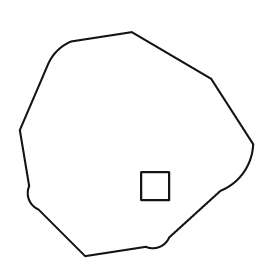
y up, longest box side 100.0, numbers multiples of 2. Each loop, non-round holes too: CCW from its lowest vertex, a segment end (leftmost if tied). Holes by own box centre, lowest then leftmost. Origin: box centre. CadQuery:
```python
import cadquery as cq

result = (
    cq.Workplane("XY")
    .moveTo(-22.0, -48.0)
    .lineTo(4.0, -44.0)
    .threePointArc((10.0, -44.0), (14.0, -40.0))
    .lineTo(36.0, -20.0)
    .threePointArc((46.0, -12.0), (50.0, 0.0))
    .lineTo(32.0, 28.0)
    .lineTo(-2.0, 48.0)
    .lineTo(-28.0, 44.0)
    .threePointArc((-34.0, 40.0), (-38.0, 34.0))
    .lineTo(-50.0, 6.0)
    .lineTo(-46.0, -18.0)
    .threePointArc((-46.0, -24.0), (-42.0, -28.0))
    .close()
    .moveTo(2.0, -24.0)
    .lineTo(14.0, -24.0)
    .lineTo(14.0, -12.0)
    .lineTo(2.0, -12.0)
    .close()
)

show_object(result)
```